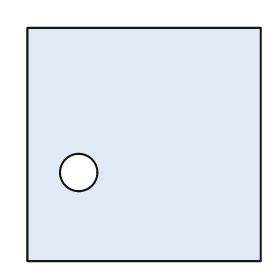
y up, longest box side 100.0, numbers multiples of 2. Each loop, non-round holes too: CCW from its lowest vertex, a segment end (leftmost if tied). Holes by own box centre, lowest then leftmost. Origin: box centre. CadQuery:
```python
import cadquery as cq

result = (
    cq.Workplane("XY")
    .moveTo(-50.0, -50.0)
    .lineTo(50.0, -50.0)
    .lineTo(50.0, 50.0)
    .lineTo(-50.0, 50.0)
    .close()
    .moveTo(-28.0, -12.0)
    .circle(8.0)
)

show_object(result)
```